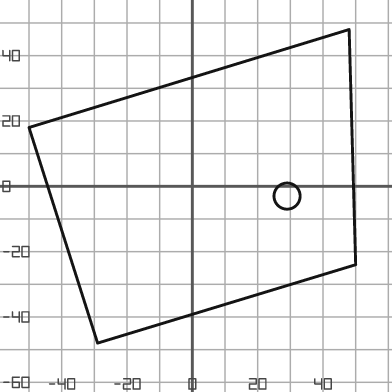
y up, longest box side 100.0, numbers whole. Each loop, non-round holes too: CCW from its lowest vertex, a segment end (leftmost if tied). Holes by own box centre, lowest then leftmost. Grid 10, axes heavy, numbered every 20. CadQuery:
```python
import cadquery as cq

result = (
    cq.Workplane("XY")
    .moveTo(-29.0, -48.0)
    .lineTo(50.0, -24.0)
    .lineTo(48.0, 48.0)
    .lineTo(-50.0, 18.0)
    .close()
    .moveTo(29.0, -3.0)
    .circle(4.0)
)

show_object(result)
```